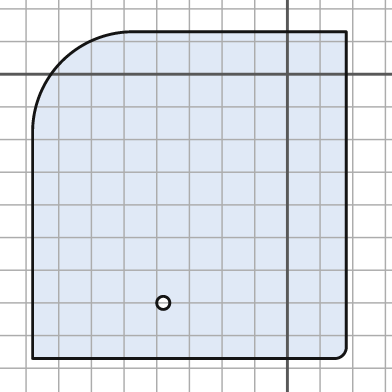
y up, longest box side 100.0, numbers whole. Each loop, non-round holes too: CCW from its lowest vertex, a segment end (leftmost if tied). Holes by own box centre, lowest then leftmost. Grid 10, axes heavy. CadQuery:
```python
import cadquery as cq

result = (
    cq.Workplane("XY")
    .moveTo(-78.0, -87.0)
    .lineTo(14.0, -87.0)
    .threePointArc((17.0, -86.0), (18.0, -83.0))
    .lineTo(18.0, 13.0)
    .lineTo(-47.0, 13.0)
    .threePointArc((-69.0, 4.0), (-78.0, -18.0))
    .close()
    .moveTo(-38.0, -70.0)
    .circle(2.0)
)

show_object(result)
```